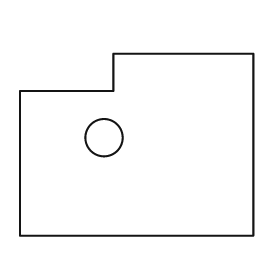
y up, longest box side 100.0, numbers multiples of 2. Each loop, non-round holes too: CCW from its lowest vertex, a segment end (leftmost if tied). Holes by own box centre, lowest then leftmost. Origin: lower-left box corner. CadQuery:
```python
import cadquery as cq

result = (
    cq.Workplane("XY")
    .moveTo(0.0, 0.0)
    .lineTo(100.0, 0.0)
    .lineTo(100.0, 78.0)
    .lineTo(40.0, 78.0)
    .lineTo(40.0, 62.0)
    .lineTo(0.0, 62.0)
    .close()
    .moveTo(36.0, 42.0)
    .circle(8.0)
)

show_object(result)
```